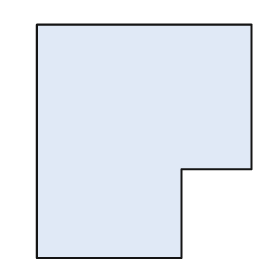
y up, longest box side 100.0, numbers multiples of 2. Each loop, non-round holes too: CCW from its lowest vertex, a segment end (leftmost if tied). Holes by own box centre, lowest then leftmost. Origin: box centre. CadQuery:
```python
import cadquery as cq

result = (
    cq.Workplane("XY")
    .moveTo(-46.0, -50.0)
    .lineTo(16.0, -50.0)
    .lineTo(16.0, -12.0)
    .lineTo(46.0, -12.0)
    .lineTo(46.0, 50.0)
    .lineTo(-46.0, 50.0)
    .close()
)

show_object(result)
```